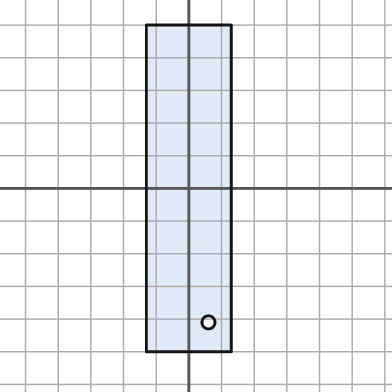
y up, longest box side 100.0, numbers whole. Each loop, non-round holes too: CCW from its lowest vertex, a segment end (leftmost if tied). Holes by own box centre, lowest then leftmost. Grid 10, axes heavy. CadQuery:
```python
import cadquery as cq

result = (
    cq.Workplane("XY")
    .moveTo(-13.0, -50.0)
    .lineTo(13.0, -50.0)
    .lineTo(13.0, 50.0)
    .lineTo(-13.0, 50.0)
    .close()
    .moveTo(6.0, -41.0)
    .circle(2.0)
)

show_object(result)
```